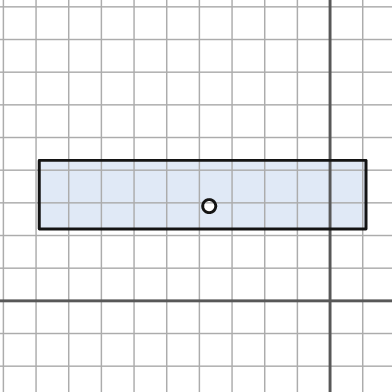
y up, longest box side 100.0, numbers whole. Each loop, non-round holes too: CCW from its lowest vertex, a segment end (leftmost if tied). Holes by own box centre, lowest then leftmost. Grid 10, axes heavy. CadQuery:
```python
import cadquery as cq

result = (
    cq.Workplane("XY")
    .moveTo(-89.0, 22.0)
    .lineTo(11.0, 22.0)
    .lineTo(11.0, 43.0)
    .lineTo(-89.0, 43.0)
    .close()
    .moveTo(-37.0, 29.0)
    .circle(2.0)
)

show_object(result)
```